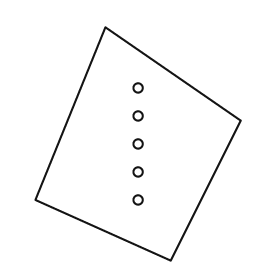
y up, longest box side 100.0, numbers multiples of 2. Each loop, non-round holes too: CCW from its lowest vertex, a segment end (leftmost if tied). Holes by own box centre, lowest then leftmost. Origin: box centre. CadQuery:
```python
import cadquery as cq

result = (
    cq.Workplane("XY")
    .moveTo(14.0, -50.0)
    .lineTo(44.0, 10.0)
    .lineTo(-14.0, 50.0)
    .lineTo(-44.0, -24.0)
    .close()
    .moveTo(0.0, -24.0)
    .circle(2.0)
    .moveTo(0.0, -12.0)
    .circle(2.0)
    .moveTo(0.0, 0.0)
    .circle(2.0)
    .moveTo(0.0, 12.0)
    .circle(2.0)
    .moveTo(0.0, 24.0)
    .circle(2.0)
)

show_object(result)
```